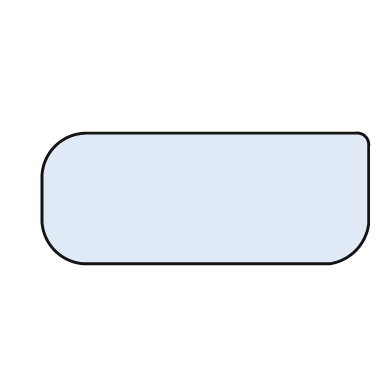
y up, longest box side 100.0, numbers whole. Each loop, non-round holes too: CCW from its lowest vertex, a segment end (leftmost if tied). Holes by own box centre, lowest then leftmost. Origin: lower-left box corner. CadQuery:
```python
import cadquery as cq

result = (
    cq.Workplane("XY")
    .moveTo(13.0, 0.0)
    .lineTo(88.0, 0.0)
    .threePointArc((96.0, 4.0), (100.0, 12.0))
    .lineTo(100.0, 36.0)
    .threePointArc((99.0, 39.0), (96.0, 40.0))
    .lineTo(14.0, 40.0)
    .threePointArc((4.0, 36.0), (0.0, 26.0))
    .lineTo(0.0, 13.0)
    .threePointArc((4.0, 4.0), (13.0, 0.0))
    .close()
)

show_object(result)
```